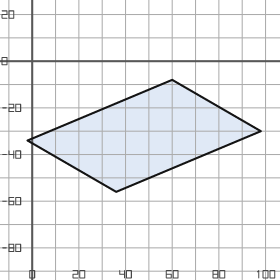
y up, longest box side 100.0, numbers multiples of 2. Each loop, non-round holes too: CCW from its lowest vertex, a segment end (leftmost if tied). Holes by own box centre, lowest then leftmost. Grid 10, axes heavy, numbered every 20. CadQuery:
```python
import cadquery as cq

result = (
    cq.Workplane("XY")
    .moveTo(36.0, -56.0)
    .lineTo(98.0, -30.0)
    .lineTo(60.0, -8.0)
    .lineTo(-2.0, -34.0)
    .close()
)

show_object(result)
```